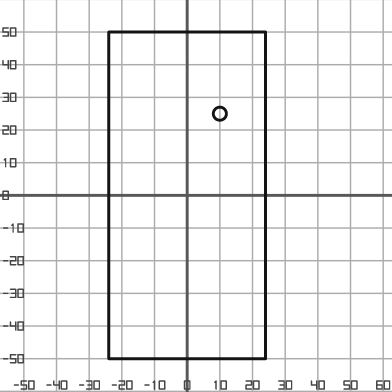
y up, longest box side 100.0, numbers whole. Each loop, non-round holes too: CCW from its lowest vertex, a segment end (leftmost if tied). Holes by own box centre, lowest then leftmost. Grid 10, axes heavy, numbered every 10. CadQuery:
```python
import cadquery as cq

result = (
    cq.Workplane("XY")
    .moveTo(-24.0, -50.0)
    .lineTo(24.0, -50.0)
    .lineTo(24.0, 50.0)
    .lineTo(-24.0, 50.0)
    .close()
    .moveTo(10.0, 25.0)
    .circle(2.0)
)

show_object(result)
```